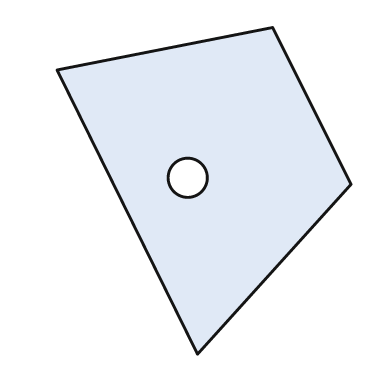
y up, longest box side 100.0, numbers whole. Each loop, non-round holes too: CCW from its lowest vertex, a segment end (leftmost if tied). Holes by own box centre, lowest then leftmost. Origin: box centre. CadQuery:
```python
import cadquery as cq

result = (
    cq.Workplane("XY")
    .moveTo(-2.0, -50.0)
    .lineTo(45.0, 2.0)
    .lineTo(21.0, 50.0)
    .lineTo(-45.0, 37.0)
    .close()
    .moveTo(-5.0, 4.0)
    .circle(6.0)
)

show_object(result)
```